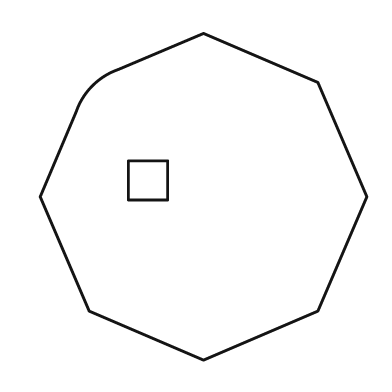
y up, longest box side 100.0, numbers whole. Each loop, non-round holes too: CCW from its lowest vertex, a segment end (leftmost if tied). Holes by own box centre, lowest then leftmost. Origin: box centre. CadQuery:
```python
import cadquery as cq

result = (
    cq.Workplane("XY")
    .moveTo(0.0, -50.0)
    .lineTo(35.0, -35.0)
    .lineTo(50.0, 0.0)
    .lineTo(35.0, 35.0)
    .lineTo(0.0, 50.0)
    .lineTo(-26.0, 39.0)
    .threePointArc((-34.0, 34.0), (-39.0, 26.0))
    .lineTo(-50.0, 0.0)
    .lineTo(-35.0, -35.0)
    .close()
    .moveTo(-23.0, -1.0)
    .lineTo(-11.0, -1.0)
    .lineTo(-11.0, 11.0)
    .lineTo(-23.0, 11.0)
    .close()
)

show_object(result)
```